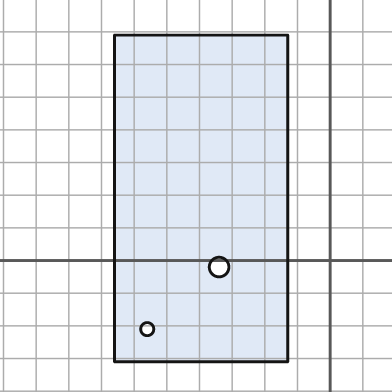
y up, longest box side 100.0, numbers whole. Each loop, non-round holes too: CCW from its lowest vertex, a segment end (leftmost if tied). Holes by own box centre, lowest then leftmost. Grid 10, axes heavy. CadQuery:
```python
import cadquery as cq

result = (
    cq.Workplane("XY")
    .moveTo(-66.0, -31.0)
    .lineTo(-13.0, -31.0)
    .lineTo(-13.0, 69.0)
    .lineTo(-66.0, 69.0)
    .close()
    .moveTo(-56.0, -21.0)
    .circle(2.0)
    .moveTo(-34.0, -2.0)
    .circle(3.0)
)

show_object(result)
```